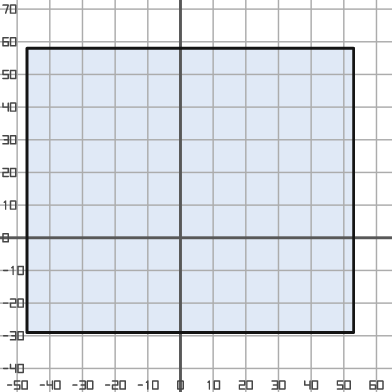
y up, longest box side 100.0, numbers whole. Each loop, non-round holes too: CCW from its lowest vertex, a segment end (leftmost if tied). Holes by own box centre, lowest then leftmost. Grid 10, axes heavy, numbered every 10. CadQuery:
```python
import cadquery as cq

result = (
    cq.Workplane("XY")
    .moveTo(-47.0, -29.0)
    .lineTo(53.0, -29.0)
    .lineTo(53.0, 58.0)
    .lineTo(-47.0, 58.0)
    .close()
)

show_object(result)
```